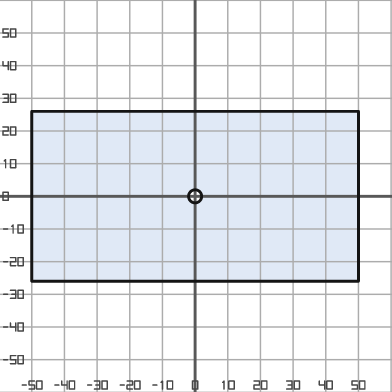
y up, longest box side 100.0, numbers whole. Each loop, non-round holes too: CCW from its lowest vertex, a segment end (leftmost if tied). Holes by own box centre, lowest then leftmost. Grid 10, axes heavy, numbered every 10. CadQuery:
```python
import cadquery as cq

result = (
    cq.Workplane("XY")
    .moveTo(-50.0, -26.0)
    .lineTo(50.0, -26.0)
    .lineTo(50.0, 26.0)
    .lineTo(-50.0, 26.0)
    .close()
    .moveTo(0.0, 0.0)
    .circle(2.0)
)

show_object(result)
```